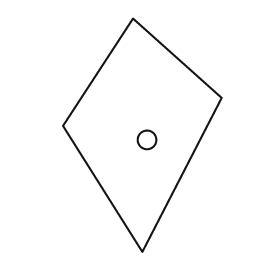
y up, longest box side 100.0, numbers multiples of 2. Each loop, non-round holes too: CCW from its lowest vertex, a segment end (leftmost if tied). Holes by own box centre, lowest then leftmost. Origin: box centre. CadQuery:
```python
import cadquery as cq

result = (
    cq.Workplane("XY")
    .moveTo(0.0, -50.0)
    .lineTo(34.0, 16.0)
    .lineTo(-4.0, 50.0)
    .lineTo(-34.0, 4.0)
    .close()
    .moveTo(2.0, -2.0)
    .circle(4.0)
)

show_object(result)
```